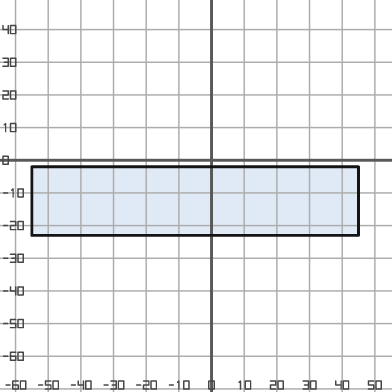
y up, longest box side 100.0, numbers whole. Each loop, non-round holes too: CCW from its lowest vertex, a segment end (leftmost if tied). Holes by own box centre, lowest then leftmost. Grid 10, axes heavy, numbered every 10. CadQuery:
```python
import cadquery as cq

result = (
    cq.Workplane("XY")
    .moveTo(-55.0, -23.0)
    .lineTo(45.0, -23.0)
    .lineTo(45.0, -2.0)
    .lineTo(-55.0, -2.0)
    .close()
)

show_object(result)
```